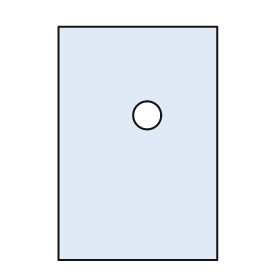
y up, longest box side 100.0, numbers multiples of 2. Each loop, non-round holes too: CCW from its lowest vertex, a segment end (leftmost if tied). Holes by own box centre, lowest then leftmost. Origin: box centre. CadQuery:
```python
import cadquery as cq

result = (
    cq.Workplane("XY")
    .moveTo(-34.0, -50.0)
    .lineTo(34.0, -50.0)
    .lineTo(34.0, 50.0)
    .lineTo(-34.0, 50.0)
    .close()
    .moveTo(4.0, 12.0)
    .circle(6.0)
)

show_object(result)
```